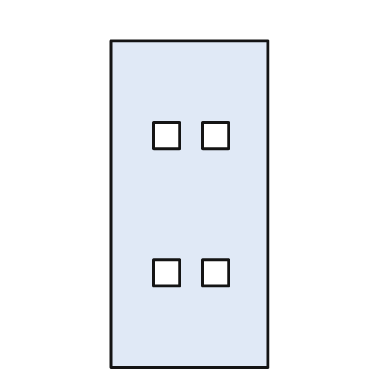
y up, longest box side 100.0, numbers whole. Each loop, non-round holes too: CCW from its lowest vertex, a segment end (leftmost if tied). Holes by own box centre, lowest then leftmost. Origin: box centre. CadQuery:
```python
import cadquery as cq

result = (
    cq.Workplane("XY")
    .moveTo(-24.0, -50.0)
    .lineTo(24.0, -50.0)
    .lineTo(24.0, 50.0)
    .lineTo(-24.0, 50.0)
    .close()
    .moveTo(-11.0, -25.0)
    .lineTo(-3.0, -25.0)
    .lineTo(-3.0, -17.0)
    .lineTo(-11.0, -17.0)
    .close()
    .moveTo(4.0, -25.0)
    .lineTo(12.0, -25.0)
    .lineTo(12.0, -17.0)
    .lineTo(4.0, -17.0)
    .close()
    .moveTo(-11.0, 17.0)
    .lineTo(-3.0, 17.0)
    .lineTo(-3.0, 25.0)
    .lineTo(-11.0, 25.0)
    .close()
    .moveTo(4.0, 17.0)
    .lineTo(12.0, 17.0)
    .lineTo(12.0, 25.0)
    .lineTo(4.0, 25.0)
    .close()
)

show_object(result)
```